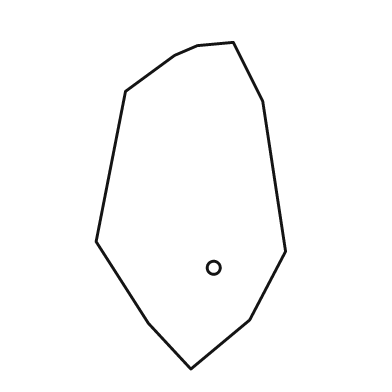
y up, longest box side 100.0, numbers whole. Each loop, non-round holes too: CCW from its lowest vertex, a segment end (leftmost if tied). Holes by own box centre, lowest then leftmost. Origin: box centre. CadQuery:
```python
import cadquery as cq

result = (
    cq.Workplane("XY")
    .moveTo(0.0, -50.0)
    .lineTo(18.0, -35.0)
    .lineTo(29.0, -14.0)
    .lineTo(22.0, 32.0)
    .lineTo(13.0, 50.0)
    .lineTo(2.0, 49.0)
    .lineTo(-5.0, 46.0)
    .lineTo(-20.0, 35.0)
    .lineTo(-29.0, -11.0)
    .lineTo(-13.0, -36.0)
    .close()
    .moveTo(7.0, -19.0)
    .circle(2.0)
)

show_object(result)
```